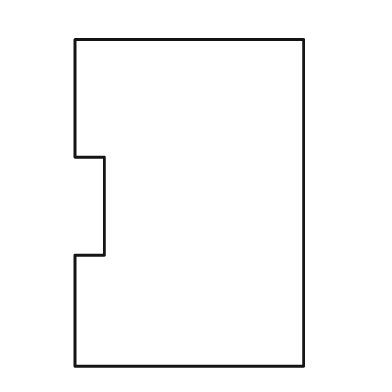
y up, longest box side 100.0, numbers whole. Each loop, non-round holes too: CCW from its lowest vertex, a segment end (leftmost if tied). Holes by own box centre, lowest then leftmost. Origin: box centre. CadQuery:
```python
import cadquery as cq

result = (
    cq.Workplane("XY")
    .moveTo(-35.0, -50.0)
    .lineTo(35.0, -50.0)
    .lineTo(35.0, 50.0)
    .lineTo(-35.0, 50.0)
    .lineTo(-35.0, 14.0)
    .lineTo(-26.0, 14.0)
    .lineTo(-26.0, -16.0)
    .lineTo(-35.0, -16.0)
    .close()
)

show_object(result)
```